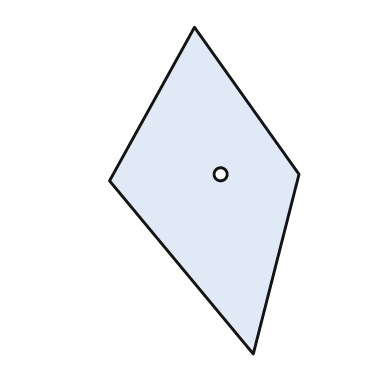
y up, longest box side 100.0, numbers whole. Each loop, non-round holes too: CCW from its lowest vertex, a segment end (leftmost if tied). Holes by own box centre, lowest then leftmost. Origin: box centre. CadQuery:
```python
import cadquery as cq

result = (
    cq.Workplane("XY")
    .moveTo(15.0, -50.0)
    .lineTo(29.0, 5.0)
    .lineTo(-3.0, 50.0)
    .lineTo(-29.0, 3.0)
    .close()
    .moveTo(5.0, 5.0)
    .circle(2.0)
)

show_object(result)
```